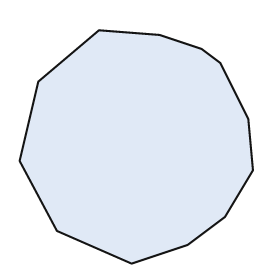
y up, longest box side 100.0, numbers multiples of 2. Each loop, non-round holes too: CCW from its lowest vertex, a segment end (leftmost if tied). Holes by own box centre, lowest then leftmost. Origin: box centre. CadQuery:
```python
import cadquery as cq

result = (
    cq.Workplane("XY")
    .moveTo(-2.0, -50.0)
    .lineTo(22.0, -42.0)
    .lineTo(38.0, -30.0)
    .lineTo(50.0, -10.0)
    .lineTo(48.0, 12.0)
    .lineTo(36.0, 36.0)
    .lineTo(28.0, 42.0)
    .lineTo(10.0, 48.0)
    .lineTo(-16.0, 50.0)
    .lineTo(-42.0, 28.0)
    .lineTo(-50.0, -6.0)
    .lineTo(-34.0, -36.0)
    .close()
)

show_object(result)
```